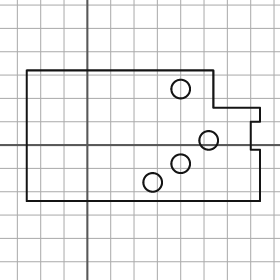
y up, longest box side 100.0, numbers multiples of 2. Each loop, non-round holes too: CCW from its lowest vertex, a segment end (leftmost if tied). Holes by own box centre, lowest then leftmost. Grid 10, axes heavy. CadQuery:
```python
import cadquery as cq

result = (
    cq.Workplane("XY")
    .moveTo(-26.0, -24.0)
    .lineTo(74.0, -24.0)
    .lineTo(74.0, -2.0)
    .lineTo(70.0, -2.0)
    .lineTo(70.0, 10.0)
    .lineTo(74.0, 10.0)
    .lineTo(74.0, 16.0)
    .lineTo(54.0, 16.0)
    .lineTo(54.0, 32.0)
    .lineTo(-26.0, 32.0)
    .close()
    .moveTo(28.0, -16.0)
    .circle(4.0)
    .moveTo(40.0, -8.0)
    .circle(4.0)
    .moveTo(52.0, 2.0)
    .circle(4.0)
    .moveTo(40.0, 24.0)
    .circle(4.0)
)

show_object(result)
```